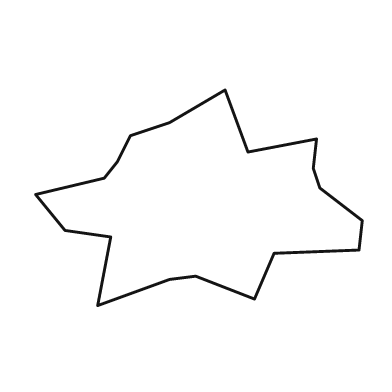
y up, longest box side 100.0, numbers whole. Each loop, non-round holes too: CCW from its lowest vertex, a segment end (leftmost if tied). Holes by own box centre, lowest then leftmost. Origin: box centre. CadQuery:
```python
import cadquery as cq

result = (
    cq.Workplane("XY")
    .moveTo(-31.0, -33.0)
    .lineTo(-9.0, -25.0)
    .lineTo(-1.0, -24.0)
    .lineTo(17.0, -31.0)
    .lineTo(23.0, -17.0)
    .lineTo(49.0, -16.0)
    .lineTo(50.0, -7.0)
    .lineTo(37.0, 3.0)
    .lineTo(35.0, 9.0)
    .lineTo(36.0, 18.0)
    .lineTo(15.0, 14.0)
    .lineTo(8.0, 33.0)
    .lineTo(-9.0, 23.0)
    .lineTo(-21.0, 19.0)
    .lineTo(-25.0, 11.0)
    .lineTo(-29.0, 6.0)
    .lineTo(-50.0, 1.0)
    .lineTo(-41.0, -10.0)
    .lineTo(-27.0, -12.0)
    .close()
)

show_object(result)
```